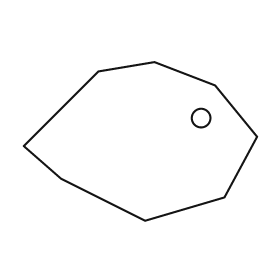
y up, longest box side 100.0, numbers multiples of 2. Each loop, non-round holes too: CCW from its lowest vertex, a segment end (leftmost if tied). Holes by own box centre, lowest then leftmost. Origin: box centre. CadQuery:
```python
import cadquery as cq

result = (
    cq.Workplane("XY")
    .moveTo(2.0, -34.0)
    .lineTo(36.0, -24.0)
    .lineTo(50.0, 2.0)
    .lineTo(32.0, 24.0)
    .lineTo(6.0, 34.0)
    .lineTo(-18.0, 30.0)
    .lineTo(-50.0, -2.0)
    .lineTo(-34.0, -16.0)
    .close()
    .moveTo(26.0, 10.0)
    .circle(4.0)
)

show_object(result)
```